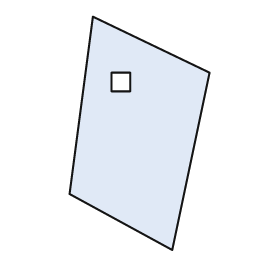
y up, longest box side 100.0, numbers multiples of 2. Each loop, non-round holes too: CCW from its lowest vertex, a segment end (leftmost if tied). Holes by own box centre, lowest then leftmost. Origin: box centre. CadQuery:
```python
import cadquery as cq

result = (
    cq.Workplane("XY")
    .moveTo(14.0, -50.0)
    .lineTo(30.0, 26.0)
    .lineTo(-20.0, 50.0)
    .lineTo(-30.0, -26.0)
    .close()
    .moveTo(-12.0, 18.0)
    .lineTo(-4.0, 18.0)
    .lineTo(-4.0, 26.0)
    .lineTo(-12.0, 26.0)
    .close()
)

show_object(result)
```